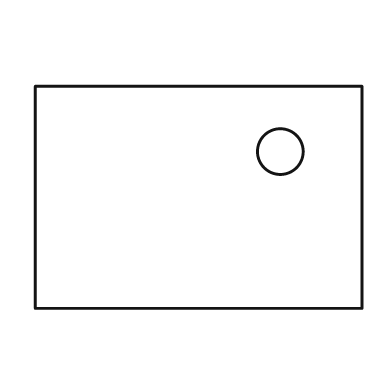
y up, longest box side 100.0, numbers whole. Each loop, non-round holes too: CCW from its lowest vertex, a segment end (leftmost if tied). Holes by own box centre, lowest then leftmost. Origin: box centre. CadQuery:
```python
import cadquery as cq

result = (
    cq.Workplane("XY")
    .moveTo(-50.0, -34.0)
    .lineTo(50.0, -34.0)
    .lineTo(50.0, 34.0)
    .lineTo(-50.0, 34.0)
    .close()
    .moveTo(25.0, 14.0)
    .circle(7.0)
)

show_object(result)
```